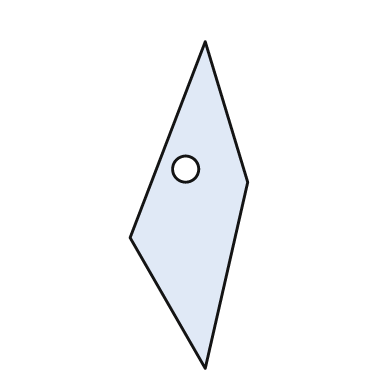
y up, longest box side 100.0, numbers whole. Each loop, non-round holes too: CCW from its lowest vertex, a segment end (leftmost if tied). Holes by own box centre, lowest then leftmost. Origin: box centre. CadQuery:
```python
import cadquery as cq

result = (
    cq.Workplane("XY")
    .moveTo(5.0, -50.0)
    .lineTo(18.0, 7.0)
    .lineTo(5.0, 50.0)
    .lineTo(-18.0, -10.0)
    .close()
    .moveTo(-1.0, 11.0)
    .circle(4.0)
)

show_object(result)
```